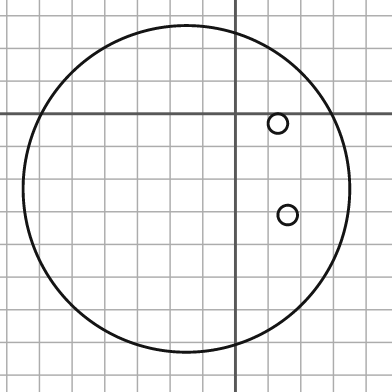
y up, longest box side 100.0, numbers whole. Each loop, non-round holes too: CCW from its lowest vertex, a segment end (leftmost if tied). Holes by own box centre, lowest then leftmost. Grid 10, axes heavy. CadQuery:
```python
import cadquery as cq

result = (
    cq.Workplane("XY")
    .moveTo(-15.0, -23.0)
    .circle(50.0)
    .moveTo(16.0, -31.0)
    .circle(3.0)
    .moveTo(13.0, -3.0)
    .circle(3.0)
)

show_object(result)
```